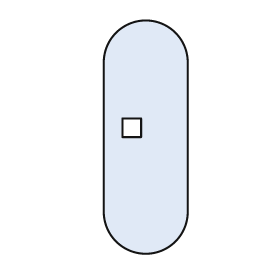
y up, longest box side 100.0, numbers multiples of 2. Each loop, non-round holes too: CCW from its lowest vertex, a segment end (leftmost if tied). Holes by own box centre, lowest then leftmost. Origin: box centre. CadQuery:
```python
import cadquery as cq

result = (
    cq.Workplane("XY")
    .moveTo(-18.0, -32.0)
    .threePointArc((0.0, -50.0), (18.0, -32.0))
    .lineTo(18.0, 32.0)
    .threePointArc((0.0, 50.0), (-18.0, 32.0))
    .close()
    .moveTo(-10.0, 0.0)
    .lineTo(-2.0, 0.0)
    .lineTo(-2.0, 8.0)
    .lineTo(-10.0, 8.0)
    .close()
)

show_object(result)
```